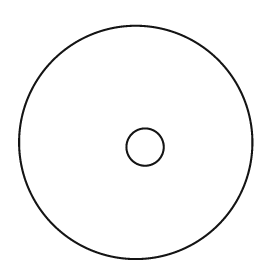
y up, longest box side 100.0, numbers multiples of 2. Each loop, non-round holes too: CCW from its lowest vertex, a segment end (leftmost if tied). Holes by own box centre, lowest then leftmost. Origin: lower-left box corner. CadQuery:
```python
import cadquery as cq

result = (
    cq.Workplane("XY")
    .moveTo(50.0, 50.0)
    .circle(50.0)
    .moveTo(54.0, 48.0)
    .circle(8.0)
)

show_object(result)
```